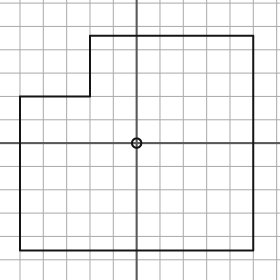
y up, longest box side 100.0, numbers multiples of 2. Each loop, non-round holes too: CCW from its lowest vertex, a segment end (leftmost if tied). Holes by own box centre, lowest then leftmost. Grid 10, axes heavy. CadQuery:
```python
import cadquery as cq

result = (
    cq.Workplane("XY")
    .moveTo(-50.0, -46.0)
    .lineTo(50.0, -46.0)
    .lineTo(50.0, 46.0)
    .lineTo(-20.0, 46.0)
    .lineTo(-20.0, 20.0)
    .lineTo(-50.0, 20.0)
    .close()
    .moveTo(0.0, 0.0)
    .circle(2.0)
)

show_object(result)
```